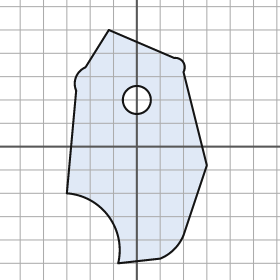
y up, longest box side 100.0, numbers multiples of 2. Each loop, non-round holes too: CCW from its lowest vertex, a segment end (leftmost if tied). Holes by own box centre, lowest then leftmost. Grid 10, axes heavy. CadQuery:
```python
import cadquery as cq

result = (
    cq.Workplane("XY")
    .moveTo(-8.0, -50.0)
    .lineTo(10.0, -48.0)
    .threePointArc((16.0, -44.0), (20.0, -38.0))
    .lineTo(30.0, -8.0)
    .lineTo(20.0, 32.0)
    .threePointArc((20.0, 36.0), (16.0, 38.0))
    .lineTo(-12.0, 50.0)
    .lineTo(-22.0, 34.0)
    .threePointArc((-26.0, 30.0), (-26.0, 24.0))
    .lineTo(-30.0, -20.0)
    .threePointArc((-12.0, -30.0), (-8.0, -50.0))
    .close()
    .moveTo(0.0, 20.0)
    .circle(6.0)
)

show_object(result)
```